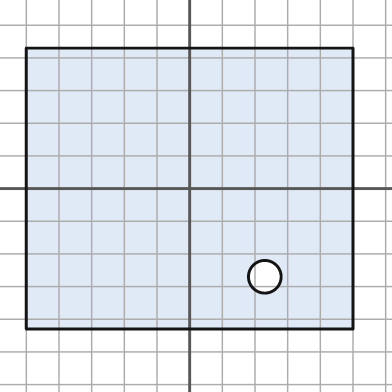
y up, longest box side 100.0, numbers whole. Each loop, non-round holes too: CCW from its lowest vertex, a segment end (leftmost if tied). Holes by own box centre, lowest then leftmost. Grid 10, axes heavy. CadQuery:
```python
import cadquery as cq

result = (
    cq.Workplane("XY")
    .moveTo(-50.0, -43.0)
    .lineTo(50.0, -43.0)
    .lineTo(50.0, 43.0)
    .lineTo(-50.0, 43.0)
    .close()
    .moveTo(23.0, -27.0)
    .circle(5.0)
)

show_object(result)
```